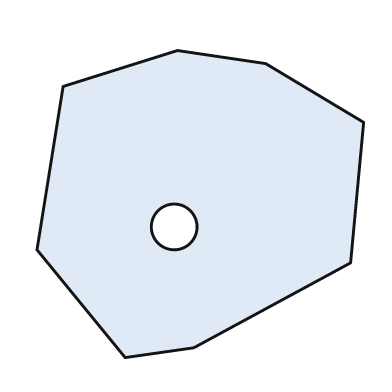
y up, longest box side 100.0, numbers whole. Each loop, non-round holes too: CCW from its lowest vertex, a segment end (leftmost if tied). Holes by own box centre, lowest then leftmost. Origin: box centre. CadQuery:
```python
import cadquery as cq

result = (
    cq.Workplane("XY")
    .moveTo(-23.0, -47.0)
    .lineTo(-2.0, -44.0)
    .lineTo(46.0, -18.0)
    .lineTo(50.0, 25.0)
    .lineTo(20.0, 43.0)
    .lineTo(-7.0, 47.0)
    .lineTo(-42.0, 36.0)
    .lineTo(-50.0, -14.0)
    .close()
    .moveTo(-8.0, -7.0)
    .circle(7.0)
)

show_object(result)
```